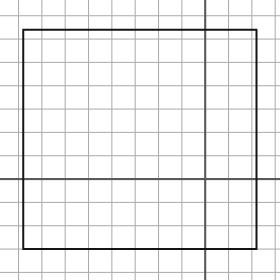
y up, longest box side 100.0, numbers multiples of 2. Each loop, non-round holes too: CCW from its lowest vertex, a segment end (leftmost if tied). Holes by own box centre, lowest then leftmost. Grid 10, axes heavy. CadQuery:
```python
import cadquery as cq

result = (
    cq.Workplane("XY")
    .moveTo(-78.0, -30.0)
    .lineTo(22.0, -30.0)
    .lineTo(22.0, 64.0)
    .lineTo(-78.0, 64.0)
    .close()
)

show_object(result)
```